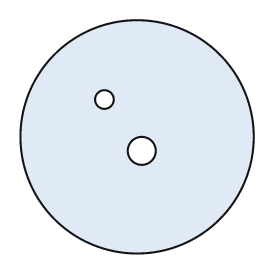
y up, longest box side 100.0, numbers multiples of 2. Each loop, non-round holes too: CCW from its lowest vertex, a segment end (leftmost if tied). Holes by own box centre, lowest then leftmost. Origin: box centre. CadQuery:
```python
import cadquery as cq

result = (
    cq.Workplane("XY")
    .moveTo(0.0, 0.0)
    .circle(50.0)
    .moveTo(2.0, -6.0)
    .circle(6.0)
    .moveTo(-14.0, 16.0)
    .circle(4.0)
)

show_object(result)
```